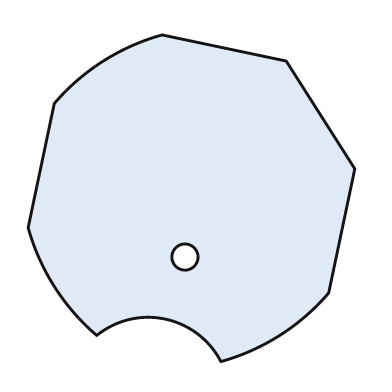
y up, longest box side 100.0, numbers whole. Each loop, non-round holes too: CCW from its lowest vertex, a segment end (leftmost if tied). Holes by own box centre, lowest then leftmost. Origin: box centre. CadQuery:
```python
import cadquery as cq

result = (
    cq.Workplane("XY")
    .moveTo(9.0, -50.0)
    .threePointArc((27.0, -42.0), (42.0, -29.0))
    .lineTo(50.0, 9.0)
    .lineTo(29.0, 42.0)
    .lineTo(-9.0, 50.0)
    .threePointArc((-27.0, 42.0), (-42.0, 29.0))
    .lineTo(-50.0, -9.0)
    .threePointArc((-42.0, -27.0), (-29.0, -42.0))
    .threePointArc((-8.0, -37.0), (9.0, -50.0))
    .close()
    .moveTo(-2.0, -18.0)
    .circle(4.0)
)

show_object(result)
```